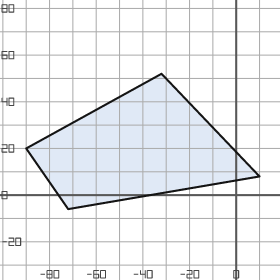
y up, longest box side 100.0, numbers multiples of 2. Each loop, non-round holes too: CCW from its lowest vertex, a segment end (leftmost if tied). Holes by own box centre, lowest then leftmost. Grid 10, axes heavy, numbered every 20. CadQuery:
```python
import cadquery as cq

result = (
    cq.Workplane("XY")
    .moveTo(-72.0, -6.0)
    .lineTo(10.0, 8.0)
    .lineTo(-32.0, 52.0)
    .lineTo(-90.0, 20.0)
    .close()
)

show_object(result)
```